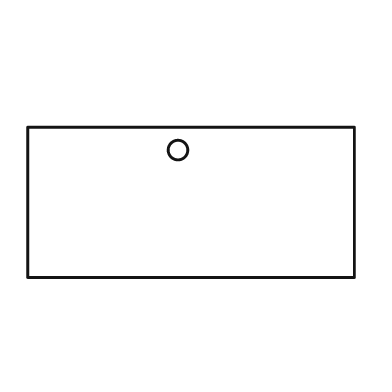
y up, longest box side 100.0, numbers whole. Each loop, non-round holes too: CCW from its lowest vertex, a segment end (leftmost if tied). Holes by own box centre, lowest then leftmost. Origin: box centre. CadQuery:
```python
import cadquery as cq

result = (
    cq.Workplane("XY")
    .moveTo(-50.0, -23.0)
    .lineTo(50.0, -23.0)
    .lineTo(50.0, 23.0)
    .lineTo(-50.0, 23.0)
    .close()
    .moveTo(-4.0, 16.0)
    .circle(3.0)
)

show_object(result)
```